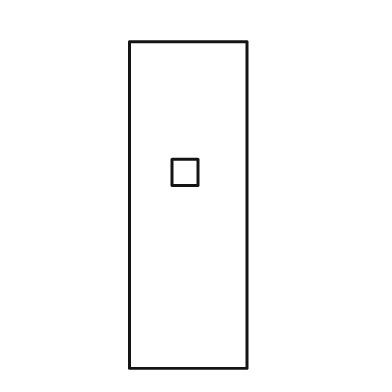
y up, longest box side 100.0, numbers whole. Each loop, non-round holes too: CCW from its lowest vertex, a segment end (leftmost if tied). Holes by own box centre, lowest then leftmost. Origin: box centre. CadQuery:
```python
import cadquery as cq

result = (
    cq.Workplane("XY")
    .moveTo(-18.0, -50.0)
    .lineTo(18.0, -50.0)
    .lineTo(18.0, 50.0)
    .lineTo(-18.0, 50.0)
    .close()
    .moveTo(-5.0, 6.0)
    .lineTo(3.0, 6.0)
    .lineTo(3.0, 14.0)
    .lineTo(-5.0, 14.0)
    .close()
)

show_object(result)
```